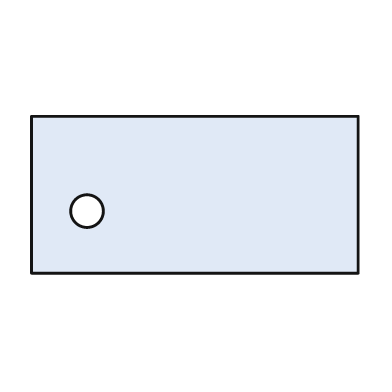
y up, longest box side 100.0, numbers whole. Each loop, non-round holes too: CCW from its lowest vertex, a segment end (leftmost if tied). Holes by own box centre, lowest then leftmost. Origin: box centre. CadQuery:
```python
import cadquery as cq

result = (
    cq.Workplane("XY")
    .moveTo(-50.0, -24.0)
    .lineTo(50.0, -24.0)
    .lineTo(50.0, 24.0)
    .lineTo(-50.0, 24.0)
    .close()
    .moveTo(-33.0, -5.0)
    .circle(5.0)
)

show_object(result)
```